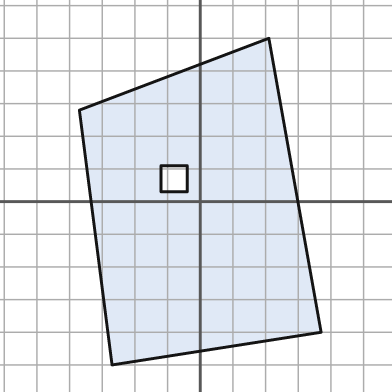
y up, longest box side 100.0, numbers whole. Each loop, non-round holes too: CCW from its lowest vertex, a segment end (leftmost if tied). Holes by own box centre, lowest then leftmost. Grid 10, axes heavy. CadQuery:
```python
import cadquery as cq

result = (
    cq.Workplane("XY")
    .moveTo(-27.0, -50.0)
    .lineTo(37.0, -40.0)
    .lineTo(21.0, 50.0)
    .lineTo(-37.0, 28.0)
    .close()
    .moveTo(-12.0, 3.0)
    .lineTo(-4.0, 3.0)
    .lineTo(-4.0, 11.0)
    .lineTo(-12.0, 11.0)
    .close()
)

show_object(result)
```